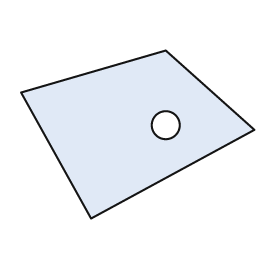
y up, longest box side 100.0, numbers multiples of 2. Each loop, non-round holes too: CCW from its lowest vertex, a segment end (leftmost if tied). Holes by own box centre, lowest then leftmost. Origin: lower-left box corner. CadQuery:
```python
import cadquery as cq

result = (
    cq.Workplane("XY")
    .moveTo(30.0, 0.0)
    .lineTo(100.0, 38.0)
    .lineTo(62.0, 72.0)
    .lineTo(0.0, 54.0)
    .close()
    .moveTo(62.0, 40.0)
    .circle(6.0)
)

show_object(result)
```